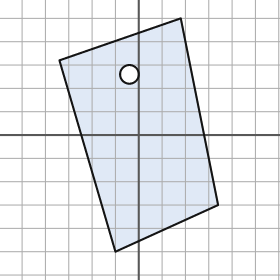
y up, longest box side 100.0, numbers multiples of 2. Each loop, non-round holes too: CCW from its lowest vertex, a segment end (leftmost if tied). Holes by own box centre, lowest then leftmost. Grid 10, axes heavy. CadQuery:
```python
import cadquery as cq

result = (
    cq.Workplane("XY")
    .moveTo(-10.0, -50.0)
    .lineTo(34.0, -30.0)
    .lineTo(18.0, 50.0)
    .lineTo(-34.0, 32.0)
    .close()
    .moveTo(-4.0, 26.0)
    .circle(4.0)
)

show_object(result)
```